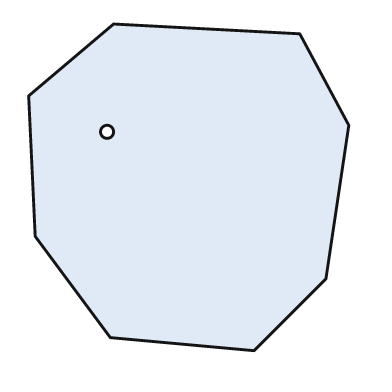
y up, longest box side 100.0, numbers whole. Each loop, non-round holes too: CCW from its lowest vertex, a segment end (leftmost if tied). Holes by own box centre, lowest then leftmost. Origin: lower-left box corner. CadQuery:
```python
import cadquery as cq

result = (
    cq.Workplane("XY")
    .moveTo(69.0, 0.0)
    .lineTo(91.0, 22.0)
    .lineTo(98.0, 69.0)
    .lineTo(83.0, 97.0)
    .lineTo(26.0, 100.0)
    .lineTo(0.0, 78.0)
    .lineTo(2.0, 35.0)
    .lineTo(25.0, 4.0)
    .close()
    .moveTo(24.0, 67.0)
    .circle(2.0)
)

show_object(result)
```